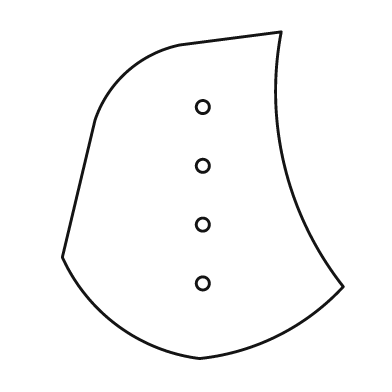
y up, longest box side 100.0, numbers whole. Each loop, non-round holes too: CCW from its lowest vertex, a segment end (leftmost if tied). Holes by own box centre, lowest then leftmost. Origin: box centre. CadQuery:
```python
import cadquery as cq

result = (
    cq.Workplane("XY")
    .moveTo(-1.0, -50.0)
    .threePointArc((23.0, -43.0), (43.0, -28.0))
    .threePointArc((25.0, 9.0), (24.0, 50.0))
    .lineTo(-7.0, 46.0)
    .threePointArc((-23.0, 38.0), (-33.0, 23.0))
    .lineTo(-43.0, -19.0)
    .threePointArc((-26.0, -40.0), (-1.0, -50.0))
    .close()
    .moveTo(0.0, -27.0)
    .circle(2.0)
    .moveTo(0.0, -9.0)
    .circle(2.0)
    .moveTo(0.0, 9.0)
    .circle(2.0)
    .moveTo(0.0, 27.0)
    .circle(2.0)
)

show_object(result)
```